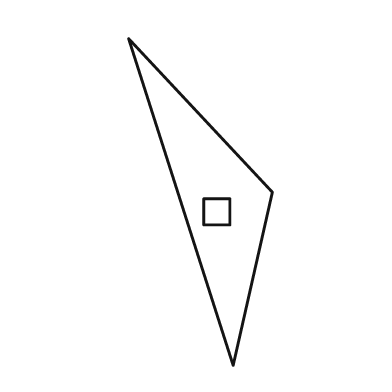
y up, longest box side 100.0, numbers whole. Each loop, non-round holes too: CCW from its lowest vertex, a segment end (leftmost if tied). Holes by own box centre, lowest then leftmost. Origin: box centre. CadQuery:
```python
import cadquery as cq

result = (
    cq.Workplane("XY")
    .moveTo(10.0, -50.0)
    .lineTo(22.0, 3.0)
    .lineTo(-22.0, 50.0)
    .close()
    .moveTo(1.0, -7.0)
    .lineTo(9.0, -7.0)
    .lineTo(9.0, 1.0)
    .lineTo(1.0, 1.0)
    .close()
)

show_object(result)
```